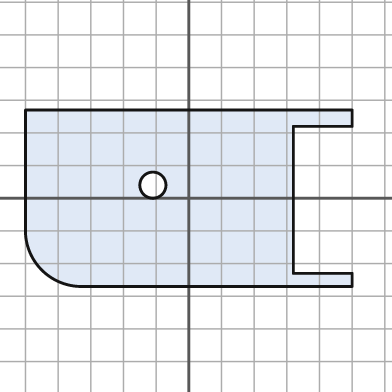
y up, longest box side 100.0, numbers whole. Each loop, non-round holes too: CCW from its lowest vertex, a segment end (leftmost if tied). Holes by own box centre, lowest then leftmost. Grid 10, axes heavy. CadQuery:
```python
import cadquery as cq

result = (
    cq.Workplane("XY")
    .moveTo(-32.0, -27.0)
    .lineTo(50.0, -27.0)
    .lineTo(50.0, -23.0)
    .lineTo(32.0, -23.0)
    .lineTo(32.0, 22.0)
    .lineTo(50.0, 22.0)
    .lineTo(50.0, 27.0)
    .lineTo(-50.0, 27.0)
    .lineTo(-50.0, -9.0)
    .threePointArc((-45.0, -22.0), (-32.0, -27.0))
    .close()
    .moveTo(-11.0, 4.0)
    .circle(4.0)
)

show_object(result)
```